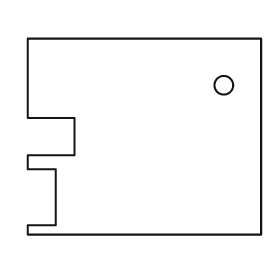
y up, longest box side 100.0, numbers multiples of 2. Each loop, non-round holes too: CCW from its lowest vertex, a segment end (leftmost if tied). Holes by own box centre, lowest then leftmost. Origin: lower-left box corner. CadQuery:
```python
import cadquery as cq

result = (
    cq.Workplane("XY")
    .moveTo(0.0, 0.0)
    .lineTo(100.0, 0.0)
    .lineTo(100.0, 84.0)
    .lineTo(0.0, 84.0)
    .lineTo(0.0, 50.0)
    .lineTo(20.0, 50.0)
    .lineTo(20.0, 34.0)
    .lineTo(0.0, 34.0)
    .lineTo(0.0, 28.0)
    .lineTo(12.0, 28.0)
    .lineTo(12.0, 4.0)
    .lineTo(0.0, 4.0)
    .close()
    .moveTo(84.0, 64.0)
    .circle(4.0)
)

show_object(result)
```